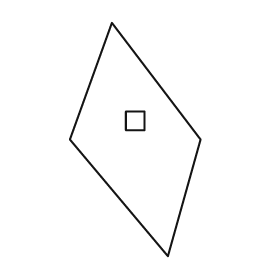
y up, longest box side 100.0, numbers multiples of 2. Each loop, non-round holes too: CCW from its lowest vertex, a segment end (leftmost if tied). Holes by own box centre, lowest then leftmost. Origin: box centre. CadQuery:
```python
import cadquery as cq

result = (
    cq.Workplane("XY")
    .moveTo(14.0, -50.0)
    .lineTo(28.0, 0.0)
    .lineTo(-10.0, 50.0)
    .lineTo(-28.0, 0.0)
    .close()
    .moveTo(-4.0, 4.0)
    .lineTo(4.0, 4.0)
    .lineTo(4.0, 12.0)
    .lineTo(-4.0, 12.0)
    .close()
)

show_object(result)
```